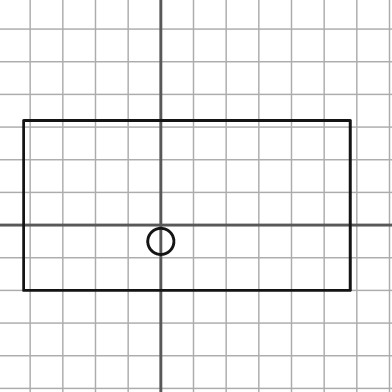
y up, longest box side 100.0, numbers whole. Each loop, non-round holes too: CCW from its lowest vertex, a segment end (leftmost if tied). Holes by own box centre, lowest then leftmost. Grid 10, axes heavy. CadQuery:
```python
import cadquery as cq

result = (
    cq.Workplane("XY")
    .moveTo(-42.0, -20.0)
    .lineTo(58.0, -20.0)
    .lineTo(58.0, 32.0)
    .lineTo(-42.0, 32.0)
    .close()
    .moveTo(0.0, -5.0)
    .circle(4.0)
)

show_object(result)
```